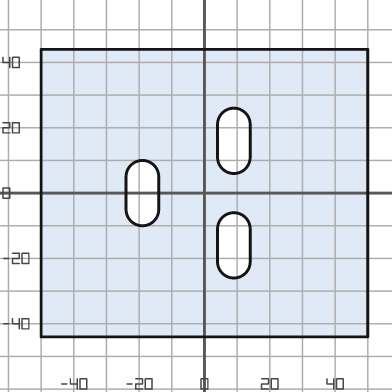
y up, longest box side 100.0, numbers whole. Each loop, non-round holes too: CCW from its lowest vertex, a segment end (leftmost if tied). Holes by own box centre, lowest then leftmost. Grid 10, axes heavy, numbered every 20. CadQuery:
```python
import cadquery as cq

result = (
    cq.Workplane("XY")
    .moveTo(-50.0, -44.0)
    .lineTo(50.0, -44.0)
    .lineTo(50.0, 44.0)
    .lineTo(-50.0, 44.0)
    .close()
    .moveTo(4.0, -21.0)
    .threePointArc((9.0, -26.0), (14.0, -21.0))
    .lineTo(14.0, -11.0)
    .threePointArc((9.0, -6.0), (4.0, -11.0))
    .close()
    .moveTo(-24.0, -5.0)
    .threePointArc((-19.0, -10.0), (-14.0, -5.0))
    .lineTo(-14.0, 5.0)
    .threePointArc((-19.0, 10.0), (-24.0, 5.0))
    .close()
    .moveTo(4.0, 11.0)
    .threePointArc((9.0, 6.0), (14.0, 11.0))
    .lineTo(14.0, 21.0)
    .threePointArc((9.0, 26.0), (4.0, 21.0))
    .close()
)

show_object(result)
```